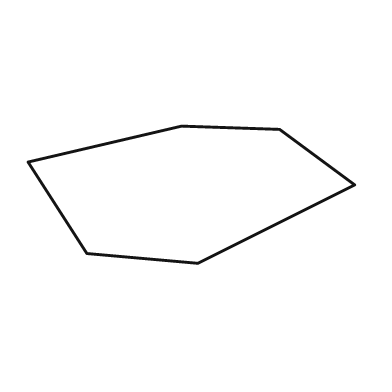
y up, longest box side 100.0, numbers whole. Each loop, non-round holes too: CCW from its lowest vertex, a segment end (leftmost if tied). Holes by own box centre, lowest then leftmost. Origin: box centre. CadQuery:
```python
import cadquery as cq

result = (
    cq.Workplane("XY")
    .moveTo(2.0, -21.0)
    .lineTo(50.0, 3.0)
    .lineTo(27.0, 20.0)
    .lineTo(-3.0, 21.0)
    .lineTo(-50.0, 10.0)
    .lineTo(-32.0, -18.0)
    .close()
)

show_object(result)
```